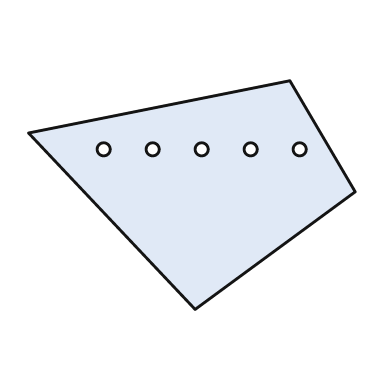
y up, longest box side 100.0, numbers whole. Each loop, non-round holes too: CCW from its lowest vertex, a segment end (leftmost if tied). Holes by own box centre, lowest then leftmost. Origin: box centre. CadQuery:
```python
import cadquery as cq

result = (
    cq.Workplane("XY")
    .moveTo(1.0, -35.0)
    .lineTo(50.0, 1.0)
    .lineTo(30.0, 35.0)
    .lineTo(-50.0, 19.0)
    .close()
    .moveTo(-27.0, 14.0)
    .circle(2.0)
    .moveTo(-12.0, 14.0)
    .circle(2.0)
    .moveTo(3.0, 14.0)
    .circle(2.0)
    .moveTo(18.0, 14.0)
    .circle(2.0)
    .moveTo(33.0, 14.0)
    .circle(2.0)
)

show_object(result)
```